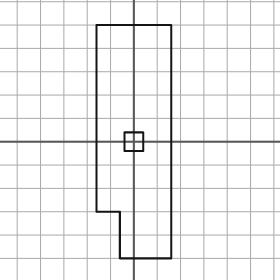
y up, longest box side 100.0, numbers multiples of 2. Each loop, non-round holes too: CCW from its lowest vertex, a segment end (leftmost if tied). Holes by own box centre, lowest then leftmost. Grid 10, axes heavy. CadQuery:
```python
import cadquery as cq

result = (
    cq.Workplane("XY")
    .moveTo(-6.0, -50.0)
    .lineTo(16.0, -50.0)
    .lineTo(16.0, 50.0)
    .lineTo(-16.0, 50.0)
    .lineTo(-16.0, -30.0)
    .lineTo(-6.0, -30.0)
    .close()
    .moveTo(-4.0, -4.0)
    .lineTo(4.0, -4.0)
    .lineTo(4.0, 4.0)
    .lineTo(-4.0, 4.0)
    .close()
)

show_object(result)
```